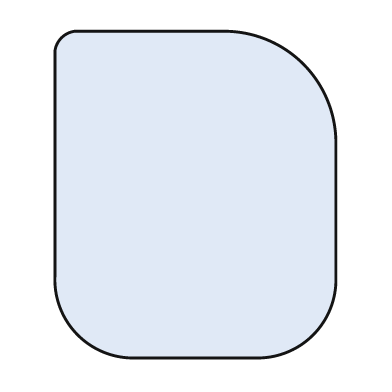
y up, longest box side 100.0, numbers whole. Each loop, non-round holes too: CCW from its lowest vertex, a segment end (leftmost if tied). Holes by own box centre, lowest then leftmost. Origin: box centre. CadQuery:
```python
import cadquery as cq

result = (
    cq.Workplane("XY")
    .moveTo(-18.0, -50.0)
    .lineTo(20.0, -50.0)
    .threePointArc((36.0, -43.0), (43.0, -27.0))
    .lineTo(43.0, 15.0)
    .threePointArc((33.0, 40.0), (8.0, 50.0))
    .lineTo(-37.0, 50.0)
    .threePointArc((-41.0, 48.0), (-43.0, 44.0))
    .lineTo(-43.0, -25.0)
    .threePointArc((-36.0, -43.0), (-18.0, -50.0))
    .close()
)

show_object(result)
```